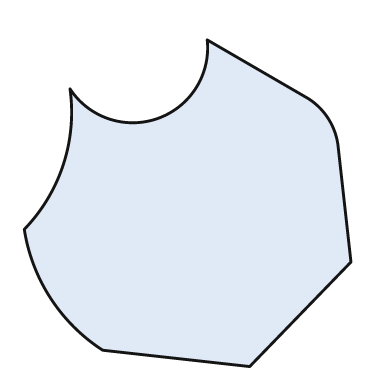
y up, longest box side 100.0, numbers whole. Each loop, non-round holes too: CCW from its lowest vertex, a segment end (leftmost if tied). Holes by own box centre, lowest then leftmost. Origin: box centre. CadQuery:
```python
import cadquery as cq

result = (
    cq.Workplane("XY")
    .moveTo(19.0, -50.0)
    .lineTo(50.0, -18.0)
    .lineTo(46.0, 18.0)
    .threePointArc((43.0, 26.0), (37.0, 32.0))
    .lineTo(6.0, 50.0)
    .threePointArc((-9.0, 26.0), (-36.0, 35.0))
    .threePointArc((-38.0, 12.0), (-50.0, -8.0))
    .threePointArc((-42.0, -29.0), (-26.0, -45.0))
    .close()
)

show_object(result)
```